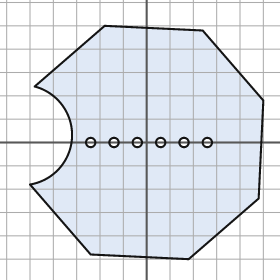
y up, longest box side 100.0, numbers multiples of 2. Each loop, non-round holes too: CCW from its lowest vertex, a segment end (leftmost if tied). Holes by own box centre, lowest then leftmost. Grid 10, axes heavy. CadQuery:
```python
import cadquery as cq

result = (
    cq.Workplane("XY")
    .moveTo(18.0, -50.0)
    .lineTo(48.0, -24.0)
    .lineTo(50.0, 18.0)
    .lineTo(24.0, 48.0)
    .lineTo(-18.0, 50.0)
    .lineTo(-48.0, 24.0)
    .threePointArc((-32.0, 2.0), (-50.0, -18.0))
    .lineTo(-24.0, -48.0)
    .close()
    .moveTo(-24.0, 0.0)
    .circle(2.0)
    .moveTo(-14.0, 0.0)
    .circle(2.0)
    .moveTo(-4.0, 0.0)
    .circle(2.0)
    .moveTo(6.0, 0.0)
    .circle(2.0)
    .moveTo(16.0, 0.0)
    .circle(2.0)
    .moveTo(26.0, 0.0)
    .circle(2.0)
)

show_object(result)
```